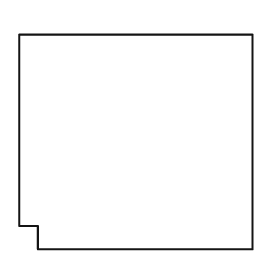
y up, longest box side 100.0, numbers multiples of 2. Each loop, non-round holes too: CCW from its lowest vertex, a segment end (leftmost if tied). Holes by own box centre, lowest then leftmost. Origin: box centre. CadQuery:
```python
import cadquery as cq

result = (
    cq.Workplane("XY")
    .moveTo(-42.0, -46.0)
    .lineTo(50.0, -46.0)
    .lineTo(50.0, 46.0)
    .lineTo(-50.0, 46.0)
    .lineTo(-50.0, -36.0)
    .lineTo(-42.0, -36.0)
    .close()
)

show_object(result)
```